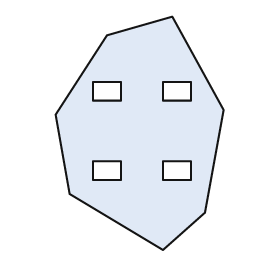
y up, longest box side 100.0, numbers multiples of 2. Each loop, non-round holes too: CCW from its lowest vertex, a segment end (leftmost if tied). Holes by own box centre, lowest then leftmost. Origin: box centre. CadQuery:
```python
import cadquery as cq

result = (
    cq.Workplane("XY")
    .moveTo(10.0, -50.0)
    .lineTo(28.0, -34.0)
    .lineTo(36.0, 10.0)
    .lineTo(14.0, 50.0)
    .lineTo(-14.0, 42.0)
    .lineTo(-36.0, 8.0)
    .lineTo(-30.0, -26.0)
    .close()
    .moveTo(-20.0, -20.0)
    .lineTo(-8.0, -20.0)
    .lineTo(-8.0, -12.0)
    .lineTo(-20.0, -12.0)
    .close()
    .moveTo(10.0, -20.0)
    .lineTo(22.0, -20.0)
    .lineTo(22.0, -12.0)
    .lineTo(10.0, -12.0)
    .close()
    .moveTo(-20.0, 14.0)
    .lineTo(-8.0, 14.0)
    .lineTo(-8.0, 22.0)
    .lineTo(-20.0, 22.0)
    .close()
    .moveTo(10.0, 14.0)
    .lineTo(22.0, 14.0)
    .lineTo(22.0, 22.0)
    .lineTo(10.0, 22.0)
    .close()
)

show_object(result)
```